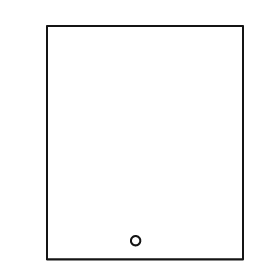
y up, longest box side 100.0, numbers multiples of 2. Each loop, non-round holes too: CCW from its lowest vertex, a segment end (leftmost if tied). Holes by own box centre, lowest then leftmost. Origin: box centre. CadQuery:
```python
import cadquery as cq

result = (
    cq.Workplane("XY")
    .moveTo(-42.0, -50.0)
    .lineTo(42.0, -50.0)
    .lineTo(42.0, 50.0)
    .lineTo(-42.0, 50.0)
    .close()
    .moveTo(-4.0, -42.0)
    .circle(2.0)
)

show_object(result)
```